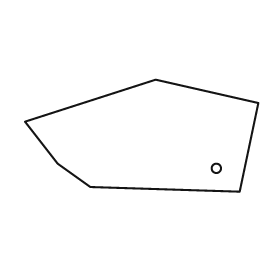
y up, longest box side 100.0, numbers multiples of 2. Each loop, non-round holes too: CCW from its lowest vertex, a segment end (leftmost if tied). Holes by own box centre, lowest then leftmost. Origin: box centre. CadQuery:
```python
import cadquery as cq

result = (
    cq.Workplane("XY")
    .moveTo(42.0, -24.0)
    .lineTo(50.0, 14.0)
    .lineTo(6.0, 24.0)
    .lineTo(-50.0, 6.0)
    .lineTo(-36.0, -12.0)
    .lineTo(-22.0, -22.0)
    .close()
    .moveTo(32.0, -14.0)
    .circle(2.0)
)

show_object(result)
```